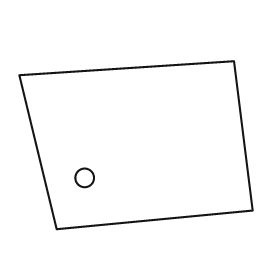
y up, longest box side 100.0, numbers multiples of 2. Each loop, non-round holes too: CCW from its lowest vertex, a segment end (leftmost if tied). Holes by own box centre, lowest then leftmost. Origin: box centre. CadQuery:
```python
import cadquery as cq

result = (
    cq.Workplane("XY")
    .moveTo(-34.0, -36.0)
    .lineTo(50.0, -28.0)
    .lineTo(42.0, 36.0)
    .lineTo(-50.0, 30.0)
    .close()
    .moveTo(-22.0, -14.0)
    .circle(4.0)
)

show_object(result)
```